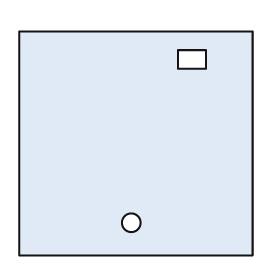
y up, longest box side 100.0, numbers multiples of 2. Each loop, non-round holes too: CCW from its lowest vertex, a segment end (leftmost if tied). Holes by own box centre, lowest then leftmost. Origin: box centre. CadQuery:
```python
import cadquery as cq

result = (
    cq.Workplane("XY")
    .moveTo(-50.0, -48.0)
    .lineTo(50.0, -48.0)
    .lineTo(50.0, 48.0)
    .lineTo(-50.0, 48.0)
    .close()
    .moveTo(-2.0, -34.0)
    .circle(4.0)
    .moveTo(18.0, 32.0)
    .lineTo(30.0, 32.0)
    .lineTo(30.0, 40.0)
    .lineTo(18.0, 40.0)
    .close()
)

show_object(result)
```